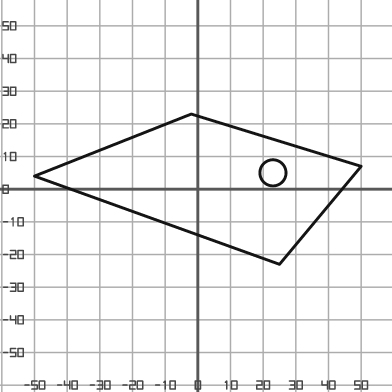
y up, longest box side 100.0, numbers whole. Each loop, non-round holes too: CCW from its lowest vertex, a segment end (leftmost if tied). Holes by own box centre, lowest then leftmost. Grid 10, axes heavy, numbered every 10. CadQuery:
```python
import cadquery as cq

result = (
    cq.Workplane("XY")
    .moveTo(25.0, -23.0)
    .lineTo(50.0, 7.0)
    .lineTo(-2.0, 23.0)
    .lineTo(-50.0, 4.0)
    .close()
    .moveTo(23.0, 5.0)
    .circle(4.0)
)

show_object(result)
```